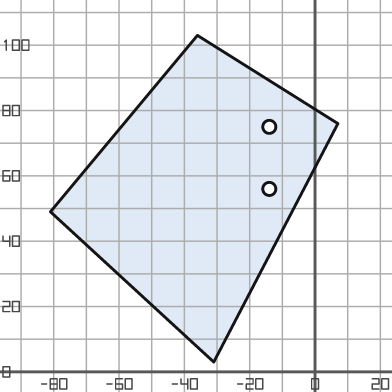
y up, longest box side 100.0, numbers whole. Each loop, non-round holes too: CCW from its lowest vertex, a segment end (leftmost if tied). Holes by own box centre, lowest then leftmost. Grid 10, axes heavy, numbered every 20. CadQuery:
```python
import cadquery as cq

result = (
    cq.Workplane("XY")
    .moveTo(-31.0, 3.0)
    .lineTo(7.0, 76.0)
    .lineTo(-36.0, 103.0)
    .lineTo(-81.0, 49.0)
    .close()
    .moveTo(-14.0, 56.0)
    .circle(2.0)
    .moveTo(-14.0, 75.0)
    .circle(2.0)
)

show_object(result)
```